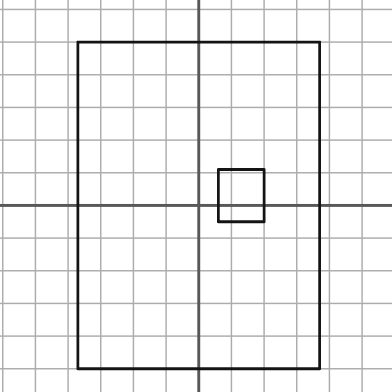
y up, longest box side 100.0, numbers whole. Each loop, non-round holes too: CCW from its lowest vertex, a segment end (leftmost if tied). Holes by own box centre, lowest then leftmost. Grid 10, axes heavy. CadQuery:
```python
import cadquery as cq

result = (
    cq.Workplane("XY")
    .moveTo(-37.0, -50.0)
    .lineTo(37.0, -50.0)
    .lineTo(37.0, 50.0)
    .lineTo(-37.0, 50.0)
    .close()
    .moveTo(6.0, -5.0)
    .lineTo(20.0, -5.0)
    .lineTo(20.0, 11.0)
    .lineTo(6.0, 11.0)
    .close()
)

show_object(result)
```